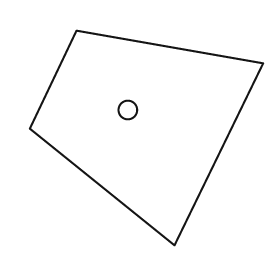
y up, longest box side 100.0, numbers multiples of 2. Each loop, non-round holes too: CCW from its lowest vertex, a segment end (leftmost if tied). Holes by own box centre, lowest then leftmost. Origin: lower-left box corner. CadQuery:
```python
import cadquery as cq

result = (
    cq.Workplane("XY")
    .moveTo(62.0, 0.0)
    .lineTo(100.0, 78.0)
    .lineTo(20.0, 92.0)
    .lineTo(0.0, 50.0)
    .close()
    .moveTo(42.0, 58.0)
    .circle(4.0)
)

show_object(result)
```